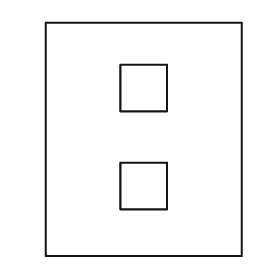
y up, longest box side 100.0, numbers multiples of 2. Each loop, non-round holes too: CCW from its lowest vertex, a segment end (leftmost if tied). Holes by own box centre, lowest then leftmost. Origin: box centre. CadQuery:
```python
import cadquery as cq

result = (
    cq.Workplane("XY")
    .moveTo(-42.0, -50.0)
    .lineTo(42.0, -50.0)
    .lineTo(42.0, 50.0)
    .lineTo(-42.0, 50.0)
    .close()
    .moveTo(-10.0, -30.0)
    .lineTo(10.0, -30.0)
    .lineTo(10.0, -10.0)
    .lineTo(-10.0, -10.0)
    .close()
    .moveTo(-10.0, 12.0)
    .lineTo(10.0, 12.0)
    .lineTo(10.0, 32.0)
    .lineTo(-10.0, 32.0)
    .close()
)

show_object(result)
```